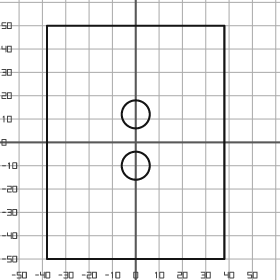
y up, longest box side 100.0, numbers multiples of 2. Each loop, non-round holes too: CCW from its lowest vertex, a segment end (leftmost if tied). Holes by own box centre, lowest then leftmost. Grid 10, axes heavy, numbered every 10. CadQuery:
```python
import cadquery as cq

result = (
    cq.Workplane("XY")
    .moveTo(-38.0, -50.0)
    .lineTo(38.0, -50.0)
    .lineTo(38.0, 50.0)
    .lineTo(-38.0, 50.0)
    .close()
    .moveTo(0.0, -10.0)
    .circle(6.0)
    .moveTo(0.0, 12.0)
    .circle(6.0)
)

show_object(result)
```